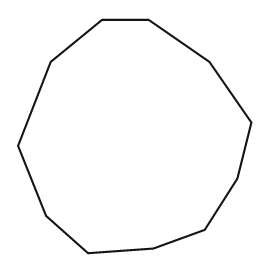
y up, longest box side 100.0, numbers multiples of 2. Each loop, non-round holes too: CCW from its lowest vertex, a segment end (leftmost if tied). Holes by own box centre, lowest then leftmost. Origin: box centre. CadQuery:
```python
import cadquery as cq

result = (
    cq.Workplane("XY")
    .moveTo(-20.0, -50.0)
    .lineTo(8.0, -48.0)
    .lineTo(30.0, -40.0)
    .lineTo(44.0, -18.0)
    .lineTo(50.0, 6.0)
    .lineTo(32.0, 32.0)
    .lineTo(6.0, 50.0)
    .lineTo(-14.0, 50.0)
    .lineTo(-36.0, 32.0)
    .lineTo(-50.0, -4.0)
    .lineTo(-38.0, -34.0)
    .close()
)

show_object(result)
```